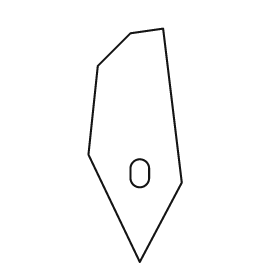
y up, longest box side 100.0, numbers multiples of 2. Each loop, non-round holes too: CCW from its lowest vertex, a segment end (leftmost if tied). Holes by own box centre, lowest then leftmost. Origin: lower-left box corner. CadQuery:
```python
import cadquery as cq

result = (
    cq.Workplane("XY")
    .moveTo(22.0, 0.0)
    .lineTo(40.0, 34.0)
    .lineTo(32.0, 100.0)
    .lineTo(18.0, 98.0)
    .lineTo(4.0, 84.0)
    .lineTo(0.0, 46.0)
    .close()
    .moveTo(18.0, 36.0)
    .threePointArc((22.0, 32.0), (26.0, 36.0))
    .lineTo(26.0, 40.0)
    .threePointArc((22.0, 44.0), (18.0, 40.0))
    .close()
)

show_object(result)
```